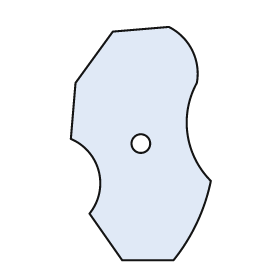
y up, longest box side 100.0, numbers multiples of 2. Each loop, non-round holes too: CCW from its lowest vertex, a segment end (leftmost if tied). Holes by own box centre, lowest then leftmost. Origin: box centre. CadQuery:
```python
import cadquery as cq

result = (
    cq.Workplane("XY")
    .moveTo(-8.0, -50.0)
    .lineTo(14.0, -50.0)
    .threePointArc((24.0, -34.0), (30.0, -16.0))
    .threePointArc((20.0, 4.0), (24.0, 26.0))
    .threePointArc((22.0, 40.0), (12.0, 50.0))
    .lineTo(-12.0, 48.0)
    .lineTo(-28.0, 26.0)
    .lineTo(-30.0, 2.0)
    .threePointArc((-18.0, -12.0), (-22.0, -30.0))
    .close()
    .moveTo(0.0, 0.0)
    .circle(4.0)
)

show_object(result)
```